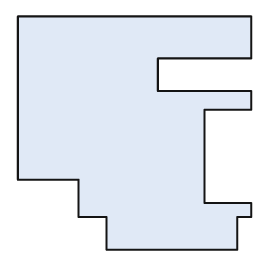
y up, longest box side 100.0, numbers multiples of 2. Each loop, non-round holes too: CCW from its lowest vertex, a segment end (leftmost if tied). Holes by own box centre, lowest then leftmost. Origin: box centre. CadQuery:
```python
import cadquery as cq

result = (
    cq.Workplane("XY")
    .moveTo(-12.0, -50.0)
    .lineTo(44.0, -50.0)
    .lineTo(44.0, -36.0)
    .lineTo(50.0, -36.0)
    .lineTo(50.0, -30.0)
    .lineTo(30.0, -30.0)
    .lineTo(30.0, 10.0)
    .lineTo(50.0, 10.0)
    .lineTo(50.0, 18.0)
    .lineTo(10.0, 18.0)
    .lineTo(10.0, 32.0)
    .lineTo(50.0, 32.0)
    .lineTo(50.0, 50.0)
    .lineTo(-50.0, 50.0)
    .lineTo(-50.0, -20.0)
    .lineTo(-24.0, -20.0)
    .lineTo(-24.0, -36.0)
    .lineTo(-12.0, -36.0)
    .close()
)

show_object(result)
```